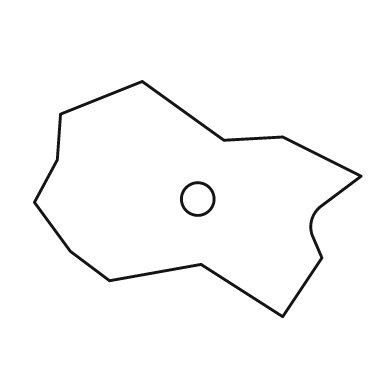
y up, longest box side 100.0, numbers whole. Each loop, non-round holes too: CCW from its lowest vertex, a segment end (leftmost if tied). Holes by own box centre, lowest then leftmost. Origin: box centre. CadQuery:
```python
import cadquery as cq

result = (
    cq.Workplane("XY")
    .moveTo(26.0, -36.0)
    .lineTo(38.0, -18.0)
    .lineTo(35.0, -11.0)
    .threePointArc((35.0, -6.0), (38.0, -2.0))
    .lineTo(50.0, 7.0)
    .lineTo(26.0, 19.0)
    .lineTo(8.0, 18.0)
    .lineTo(-17.0, 36.0)
    .lineTo(-42.0, 26.0)
    .lineTo(-43.0, 12.0)
    .lineTo(-50.0, -1.0)
    .lineTo(-39.0, -16.0)
    .lineTo(-27.0, -25.0)
    .lineTo(1.0, -20.0)
    .close()
    .moveTo(0.0, 0.0)
    .circle(5.0)
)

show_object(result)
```